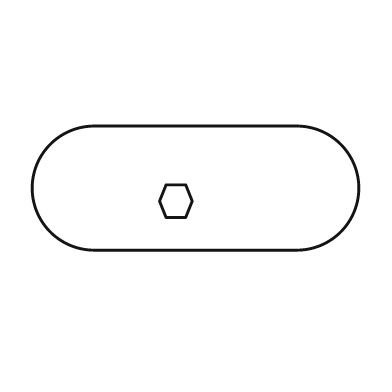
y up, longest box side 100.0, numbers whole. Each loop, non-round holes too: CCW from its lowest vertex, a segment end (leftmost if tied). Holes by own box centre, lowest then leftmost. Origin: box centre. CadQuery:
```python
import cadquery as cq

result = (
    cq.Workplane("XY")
    .moveTo(-31.0, -19.0)
    .lineTo(31.0, -19.0)
    .threePointArc((50.0, 0.0), (31.0, 19.0))
    .lineTo(-31.0, 19.0)
    .threePointArc((-50.0, 0.0), (-31.0, -19.0))
    .close()
    .moveTo(-9.0, -9.0)
    .lineTo(-3.0, -9.0)
    .lineTo(-1.0, -4.0)
    .lineTo(-3.0, 1.0)
    .lineTo(-9.0, 1.0)
    .lineTo(-11.0, -4.0)
    .close()
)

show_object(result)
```